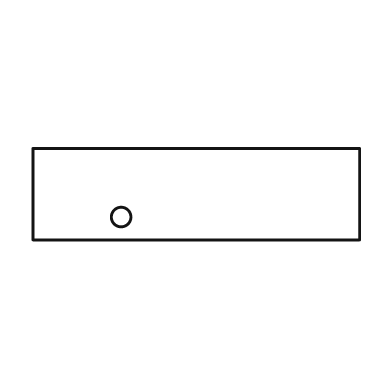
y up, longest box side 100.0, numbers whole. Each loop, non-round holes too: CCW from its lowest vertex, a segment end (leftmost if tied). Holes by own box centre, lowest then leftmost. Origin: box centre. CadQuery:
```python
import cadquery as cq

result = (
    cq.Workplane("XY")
    .moveTo(-50.0, -14.0)
    .lineTo(50.0, -14.0)
    .lineTo(50.0, 14.0)
    .lineTo(-50.0, 14.0)
    .close()
    .moveTo(-23.0, -7.0)
    .circle(3.0)
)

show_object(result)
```